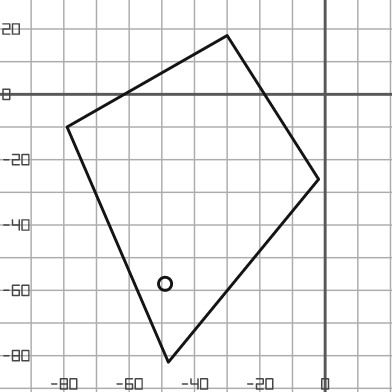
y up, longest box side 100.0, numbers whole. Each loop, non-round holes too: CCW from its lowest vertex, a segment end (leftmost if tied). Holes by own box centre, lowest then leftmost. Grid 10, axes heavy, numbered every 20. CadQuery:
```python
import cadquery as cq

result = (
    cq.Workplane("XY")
    .moveTo(-48.0, -82.0)
    .lineTo(-2.0, -26.0)
    .lineTo(-30.0, 18.0)
    .lineTo(-79.0, -10.0)
    .close()
    .moveTo(-49.0, -58.0)
    .circle(2.0)
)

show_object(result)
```